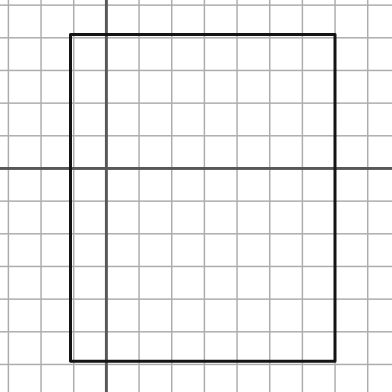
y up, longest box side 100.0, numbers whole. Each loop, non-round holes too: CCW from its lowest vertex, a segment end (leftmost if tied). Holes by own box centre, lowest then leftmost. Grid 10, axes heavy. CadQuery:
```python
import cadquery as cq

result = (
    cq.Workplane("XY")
    .moveTo(-11.0, -59.0)
    .lineTo(70.0, -59.0)
    .lineTo(70.0, 41.0)
    .lineTo(-11.0, 41.0)
    .close()
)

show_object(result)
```